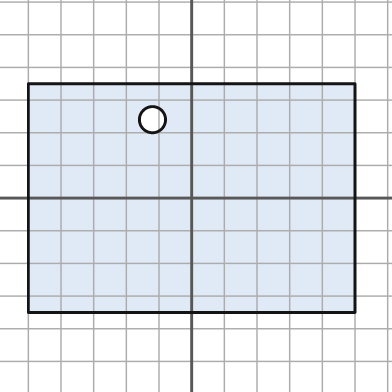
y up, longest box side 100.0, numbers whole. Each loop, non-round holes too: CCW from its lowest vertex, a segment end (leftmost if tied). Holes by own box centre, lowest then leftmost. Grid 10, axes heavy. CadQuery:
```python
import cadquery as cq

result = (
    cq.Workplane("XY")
    .moveTo(-50.0, -35.0)
    .lineTo(50.0, -35.0)
    .lineTo(50.0, 35.0)
    .lineTo(-50.0, 35.0)
    .close()
    .moveTo(-12.0, 24.0)
    .circle(4.0)
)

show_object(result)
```